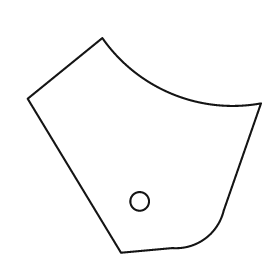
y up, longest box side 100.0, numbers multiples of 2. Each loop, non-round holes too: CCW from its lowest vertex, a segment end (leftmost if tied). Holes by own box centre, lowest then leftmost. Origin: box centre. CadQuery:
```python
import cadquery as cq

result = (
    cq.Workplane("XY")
    .moveTo(-10.0, -46.0)
    .lineTo(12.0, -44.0)
    .threePointArc((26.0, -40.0), (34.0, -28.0))
    .lineTo(50.0, 18.0)
    .threePointArc((12.0, 22.0), (-18.0, 46.0))
    .lineTo(-50.0, 20.0)
    .close()
    .moveTo(-2.0, -24.0)
    .circle(4.0)
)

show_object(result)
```